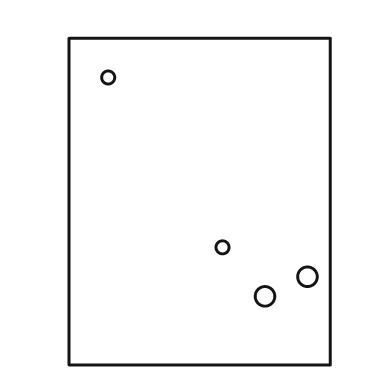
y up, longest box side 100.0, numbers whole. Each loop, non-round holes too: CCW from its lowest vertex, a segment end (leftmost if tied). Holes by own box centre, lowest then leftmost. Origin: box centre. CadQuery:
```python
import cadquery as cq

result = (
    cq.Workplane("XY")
    .moveTo(-40.0, -50.0)
    .lineTo(40.0, -50.0)
    .lineTo(40.0, 50.0)
    .lineTo(-40.0, 50.0)
    .close()
    .moveTo(20.0, -29.0)
    .circle(3.0)
    .moveTo(33.0, -23.0)
    .circle(3.0)
    .moveTo(7.0, -14.0)
    .circle(2.0)
    .moveTo(-28.0, 38.0)
    .circle(2.0)
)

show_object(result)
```